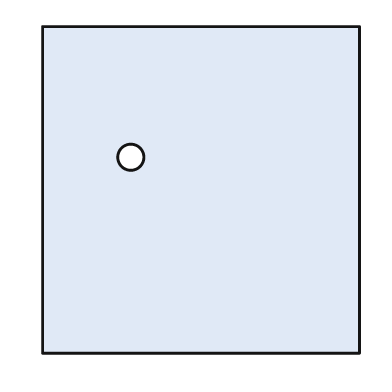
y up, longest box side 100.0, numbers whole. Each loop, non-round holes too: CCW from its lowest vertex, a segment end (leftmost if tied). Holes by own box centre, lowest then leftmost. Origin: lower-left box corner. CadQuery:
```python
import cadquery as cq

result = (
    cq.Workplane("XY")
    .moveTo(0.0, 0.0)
    .lineTo(97.0, 0.0)
    .lineTo(97.0, 100.0)
    .lineTo(0.0, 100.0)
    .close()
    .moveTo(27.0, 60.0)
    .circle(4.0)
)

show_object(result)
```